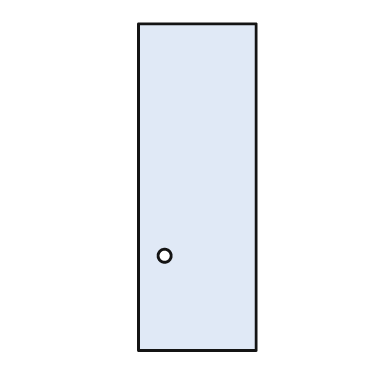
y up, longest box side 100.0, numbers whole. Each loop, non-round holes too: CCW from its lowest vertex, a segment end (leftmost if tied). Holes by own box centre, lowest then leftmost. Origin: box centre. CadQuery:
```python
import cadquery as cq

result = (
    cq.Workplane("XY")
    .moveTo(-18.0, -50.0)
    .lineTo(18.0, -50.0)
    .lineTo(18.0, 50.0)
    .lineTo(-18.0, 50.0)
    .close()
    .moveTo(-10.0, -21.0)
    .circle(2.0)
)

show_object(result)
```